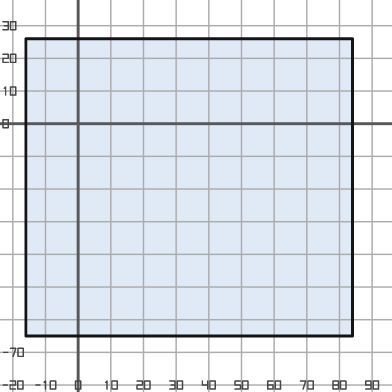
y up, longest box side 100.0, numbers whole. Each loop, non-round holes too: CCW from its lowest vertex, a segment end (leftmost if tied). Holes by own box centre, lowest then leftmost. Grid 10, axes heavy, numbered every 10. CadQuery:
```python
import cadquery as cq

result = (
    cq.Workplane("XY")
    .moveTo(-16.0, -65.0)
    .lineTo(84.0, -65.0)
    .lineTo(84.0, 26.0)
    .lineTo(-16.0, 26.0)
    .close()
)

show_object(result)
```